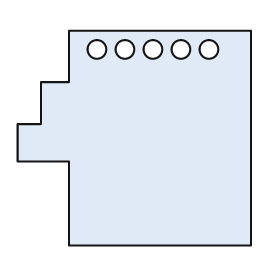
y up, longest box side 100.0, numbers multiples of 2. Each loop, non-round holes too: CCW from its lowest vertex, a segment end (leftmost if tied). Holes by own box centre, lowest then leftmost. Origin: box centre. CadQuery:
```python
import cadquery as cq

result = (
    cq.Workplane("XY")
    .moveTo(-28.0, -46.0)
    .lineTo(50.0, -46.0)
    .lineTo(50.0, 46.0)
    .lineTo(-28.0, 46.0)
    .lineTo(-28.0, 24.0)
    .lineTo(-40.0, 24.0)
    .lineTo(-40.0, 6.0)
    .lineTo(-50.0, 6.0)
    .lineTo(-50.0, -10.0)
    .lineTo(-28.0, -10.0)
    .close()
    .moveTo(-16.0, 38.0)
    .circle(4.0)
    .moveTo(-4.0, 38.0)
    .circle(4.0)
    .moveTo(8.0, 38.0)
    .circle(4.0)
    .moveTo(20.0, 38.0)
    .circle(4.0)
    .moveTo(32.0, 38.0)
    .circle(4.0)
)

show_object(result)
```